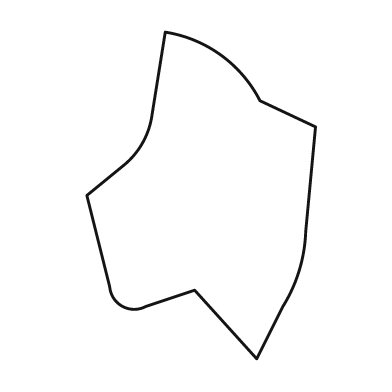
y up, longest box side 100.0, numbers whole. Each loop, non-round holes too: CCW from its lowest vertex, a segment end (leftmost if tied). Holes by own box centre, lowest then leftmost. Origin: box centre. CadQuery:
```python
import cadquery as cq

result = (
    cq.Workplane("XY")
    .moveTo(17.0, -50.0)
    .lineTo(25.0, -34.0)
    .threePointArc((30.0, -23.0), (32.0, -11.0))
    .lineTo(35.0, 21.0)
    .lineTo(18.0, 29.0)
    .threePointArc((6.0, 43.0), (-11.0, 50.0))
    .lineTo(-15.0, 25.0)
    .threePointArc((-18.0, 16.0), (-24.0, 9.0))
    .lineTo(-35.0, 0.0)
    .lineTo(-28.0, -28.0)
    .threePointArc((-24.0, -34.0), (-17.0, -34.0))
    .lineTo(-2.0, -29.0)
    .close()
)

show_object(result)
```